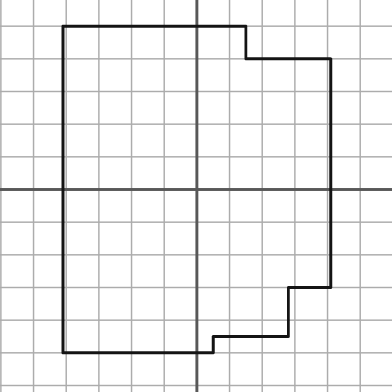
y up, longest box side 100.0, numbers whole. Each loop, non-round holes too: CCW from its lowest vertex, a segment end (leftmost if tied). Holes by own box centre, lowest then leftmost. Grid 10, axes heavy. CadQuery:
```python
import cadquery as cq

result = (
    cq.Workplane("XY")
    .moveTo(-41.0, -50.0)
    .lineTo(5.0, -50.0)
    .lineTo(5.0, -45.0)
    .lineTo(28.0, -45.0)
    .lineTo(28.0, -30.0)
    .lineTo(41.0, -30.0)
    .lineTo(41.0, 40.0)
    .lineTo(15.0, 40.0)
    .lineTo(15.0, 50.0)
    .lineTo(-41.0, 50.0)
    .close()
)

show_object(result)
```